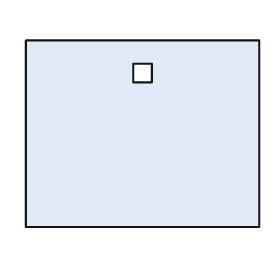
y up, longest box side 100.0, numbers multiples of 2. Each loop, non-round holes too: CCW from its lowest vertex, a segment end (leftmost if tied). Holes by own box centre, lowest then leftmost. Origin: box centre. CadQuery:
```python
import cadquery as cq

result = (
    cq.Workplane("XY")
    .moveTo(-50.0, -40.0)
    .lineTo(50.0, -40.0)
    .lineTo(50.0, 40.0)
    .lineTo(-50.0, 40.0)
    .close()
    .moveTo(-4.0, 22.0)
    .lineTo(4.0, 22.0)
    .lineTo(4.0, 30.0)
    .lineTo(-4.0, 30.0)
    .close()
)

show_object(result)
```